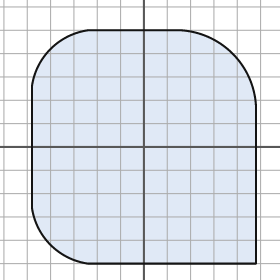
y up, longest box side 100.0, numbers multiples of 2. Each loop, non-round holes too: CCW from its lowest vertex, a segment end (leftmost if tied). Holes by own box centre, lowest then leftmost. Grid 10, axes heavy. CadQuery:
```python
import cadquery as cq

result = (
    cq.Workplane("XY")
    .moveTo(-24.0, -50.0)
    .lineTo(48.0, -50.0)
    .lineTo(48.0, 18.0)
    .threePointArc((38.0, 40.0), (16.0, 50.0))
    .lineTo(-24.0, 50.0)
    .threePointArc((-40.0, 42.0), (-48.0, 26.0))
    .lineTo(-48.0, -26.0)
    .threePointArc((-40.0, -42.0), (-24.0, -50.0))
    .close()
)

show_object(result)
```